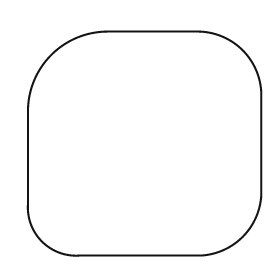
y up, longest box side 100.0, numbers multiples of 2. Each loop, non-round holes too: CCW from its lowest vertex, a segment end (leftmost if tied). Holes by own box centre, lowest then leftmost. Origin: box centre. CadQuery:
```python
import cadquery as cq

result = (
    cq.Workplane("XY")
    .moveTo(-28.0, -48.0)
    .lineTo(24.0, -48.0)
    .threePointArc((42.0, -40.0), (50.0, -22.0))
    .lineTo(50.0, 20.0)
    .threePointArc((42.0, 40.0), (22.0, 48.0))
    .lineTo(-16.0, 48.0)
    .threePointArc((-40.0, 38.0), (-50.0, 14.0))
    .lineTo(-50.0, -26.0)
    .threePointArc((-44.0, -42.0), (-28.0, -48.0))
    .close()
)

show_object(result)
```